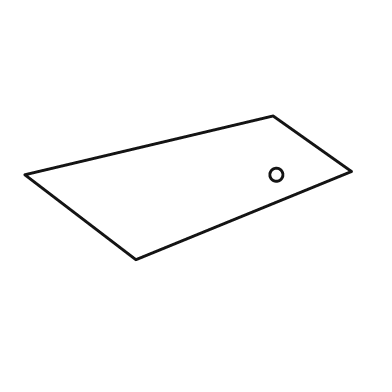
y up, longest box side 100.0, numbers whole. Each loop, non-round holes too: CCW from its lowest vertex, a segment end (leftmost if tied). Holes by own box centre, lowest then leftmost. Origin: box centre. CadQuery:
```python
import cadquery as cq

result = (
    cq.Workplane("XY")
    .moveTo(-16.0, -22.0)
    .lineTo(50.0, 5.0)
    .lineTo(26.0, 22.0)
    .lineTo(-50.0, 4.0)
    .close()
    .moveTo(27.0, 4.0)
    .circle(2.0)
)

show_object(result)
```